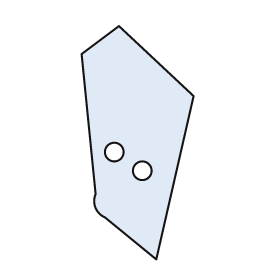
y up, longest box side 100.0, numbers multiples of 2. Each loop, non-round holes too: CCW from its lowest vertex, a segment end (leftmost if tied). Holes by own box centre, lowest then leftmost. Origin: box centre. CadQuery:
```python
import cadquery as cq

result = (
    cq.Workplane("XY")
    .moveTo(8.0, -50.0)
    .lineTo(24.0, 20.0)
    .lineTo(-8.0, 50.0)
    .lineTo(-24.0, 38.0)
    .lineTo(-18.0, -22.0)
    .threePointArc((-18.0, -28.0), (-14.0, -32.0))
    .close()
    .moveTo(2.0, -12.0)
    .circle(4.0)
    .moveTo(-10.0, -4.0)
    .circle(4.0)
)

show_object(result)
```